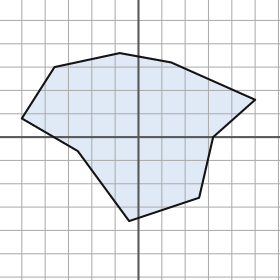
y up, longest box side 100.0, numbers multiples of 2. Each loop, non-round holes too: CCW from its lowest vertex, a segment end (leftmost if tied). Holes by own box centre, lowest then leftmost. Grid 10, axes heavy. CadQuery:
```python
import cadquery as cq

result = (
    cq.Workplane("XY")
    .moveTo(-4.0, -36.0)
    .lineTo(26.0, -26.0)
    .lineTo(32.0, 0.0)
    .lineTo(50.0, 16.0)
    .lineTo(14.0, 32.0)
    .lineTo(-8.0, 36.0)
    .lineTo(-36.0, 30.0)
    .lineTo(-50.0, 8.0)
    .lineTo(-26.0, -6.0)
    .close()
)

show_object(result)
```